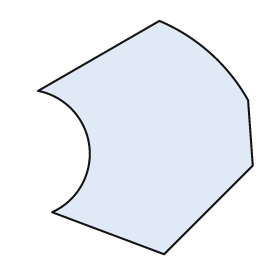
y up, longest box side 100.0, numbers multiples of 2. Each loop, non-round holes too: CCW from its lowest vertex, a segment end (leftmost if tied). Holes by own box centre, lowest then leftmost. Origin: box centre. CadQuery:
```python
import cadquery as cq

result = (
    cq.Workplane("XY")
    .moveTo(8.0, -50.0)
    .lineTo(46.0, -12.0)
    .lineTo(44.0, 16.0)
    .threePointArc((28.0, 36.0), (6.0, 50.0))
    .lineTo(-46.0, 20.0)
    .threePointArc((-24.0, -4.0), (-40.0, -32.0))
    .close()
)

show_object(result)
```